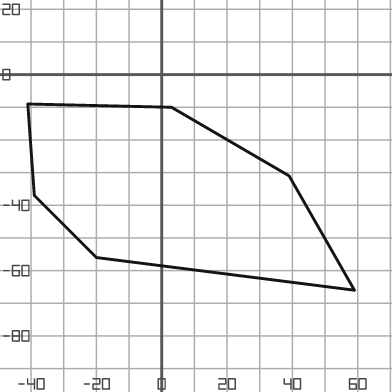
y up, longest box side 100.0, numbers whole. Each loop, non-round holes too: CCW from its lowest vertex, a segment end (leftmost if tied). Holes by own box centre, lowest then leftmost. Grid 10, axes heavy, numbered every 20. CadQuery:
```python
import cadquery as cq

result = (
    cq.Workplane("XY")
    .moveTo(59.0, -66.0)
    .lineTo(39.0, -31.0)
    .lineTo(3.0, -10.0)
    .lineTo(-41.0, -9.0)
    .lineTo(-39.0, -37.0)
    .lineTo(-20.0, -56.0)
    .close()
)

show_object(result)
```